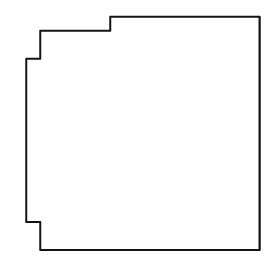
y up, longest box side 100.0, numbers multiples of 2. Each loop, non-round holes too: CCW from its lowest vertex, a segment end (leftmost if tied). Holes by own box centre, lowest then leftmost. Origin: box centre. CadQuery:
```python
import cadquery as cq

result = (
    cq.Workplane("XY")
    .moveTo(-44.0, -50.0)
    .lineTo(50.0, -50.0)
    .lineTo(50.0, 50.0)
    .lineTo(-14.0, 50.0)
    .lineTo(-14.0, 44.0)
    .lineTo(-44.0, 44.0)
    .lineTo(-44.0, 32.0)
    .lineTo(-50.0, 32.0)
    .lineTo(-50.0, -38.0)
    .lineTo(-44.0, -38.0)
    .close()
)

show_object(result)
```